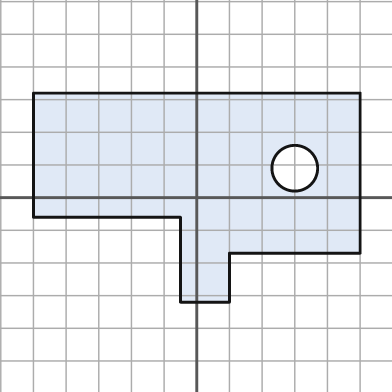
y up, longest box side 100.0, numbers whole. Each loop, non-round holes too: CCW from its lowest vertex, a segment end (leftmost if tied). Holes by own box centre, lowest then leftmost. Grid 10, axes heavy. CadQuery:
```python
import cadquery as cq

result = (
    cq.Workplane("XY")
    .moveTo(-5.0, -32.0)
    .lineTo(10.0, -32.0)
    .lineTo(10.0, -17.0)
    .lineTo(50.0, -17.0)
    .lineTo(50.0, 32.0)
    .lineTo(-50.0, 32.0)
    .lineTo(-50.0, -6.0)
    .lineTo(-5.0, -6.0)
    .close()
    .moveTo(30.0, 9.0)
    .circle(7.0)
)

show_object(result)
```